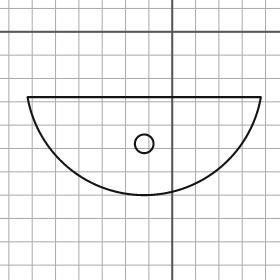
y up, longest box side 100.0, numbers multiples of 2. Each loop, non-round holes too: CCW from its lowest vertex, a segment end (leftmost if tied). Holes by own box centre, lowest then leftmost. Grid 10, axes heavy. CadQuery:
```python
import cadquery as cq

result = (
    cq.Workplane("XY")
    .moveTo(-62.0, -28.0)
    .threePointArc((-12.0, -70.0), (38.0, -28.0))
    .close()
    .moveTo(-12.0, -48.0)
    .circle(4.0)
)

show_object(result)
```